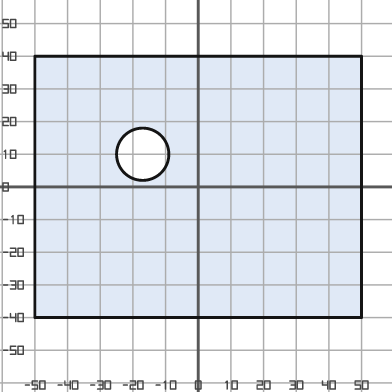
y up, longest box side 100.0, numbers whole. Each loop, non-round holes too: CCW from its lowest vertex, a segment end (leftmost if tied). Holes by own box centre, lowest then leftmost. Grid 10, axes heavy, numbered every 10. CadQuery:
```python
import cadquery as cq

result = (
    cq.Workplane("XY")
    .moveTo(-50.0, -40.0)
    .lineTo(50.0, -40.0)
    .lineTo(50.0, 40.0)
    .lineTo(-50.0, 40.0)
    .close()
    .moveTo(-17.0, 10.0)
    .circle(8.0)
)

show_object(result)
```